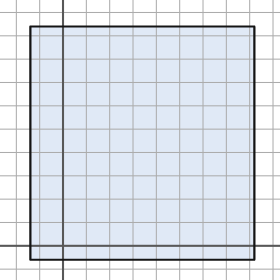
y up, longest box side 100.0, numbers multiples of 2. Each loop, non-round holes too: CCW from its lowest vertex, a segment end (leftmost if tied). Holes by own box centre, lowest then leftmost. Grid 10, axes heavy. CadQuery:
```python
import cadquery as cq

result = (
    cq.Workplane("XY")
    .moveTo(-14.0, -6.0)
    .lineTo(82.0, -6.0)
    .lineTo(82.0, 94.0)
    .lineTo(-14.0, 94.0)
    .close()
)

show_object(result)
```